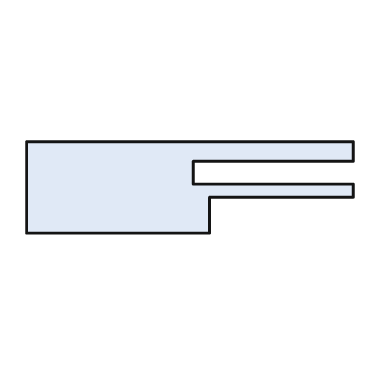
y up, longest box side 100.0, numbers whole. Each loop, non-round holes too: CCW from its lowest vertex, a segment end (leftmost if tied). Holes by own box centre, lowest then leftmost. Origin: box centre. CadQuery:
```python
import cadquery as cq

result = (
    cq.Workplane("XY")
    .moveTo(-50.0, -14.0)
    .lineTo(6.0, -14.0)
    .lineTo(6.0, -3.0)
    .lineTo(50.0, -3.0)
    .lineTo(50.0, 1.0)
    .lineTo(1.0, 1.0)
    .lineTo(1.0, 8.0)
    .lineTo(50.0, 8.0)
    .lineTo(50.0, 14.0)
    .lineTo(-50.0, 14.0)
    .close()
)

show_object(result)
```